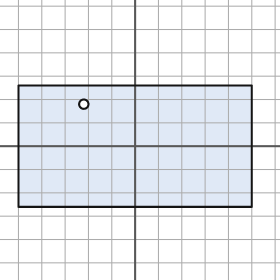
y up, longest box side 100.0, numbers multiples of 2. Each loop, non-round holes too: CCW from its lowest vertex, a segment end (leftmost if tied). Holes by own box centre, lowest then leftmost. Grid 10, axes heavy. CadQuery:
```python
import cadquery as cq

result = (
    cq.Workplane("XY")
    .moveTo(-50.0, -26.0)
    .lineTo(50.0, -26.0)
    .lineTo(50.0, 26.0)
    .lineTo(-50.0, 26.0)
    .close()
    .moveTo(-22.0, 18.0)
    .circle(2.0)
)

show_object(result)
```